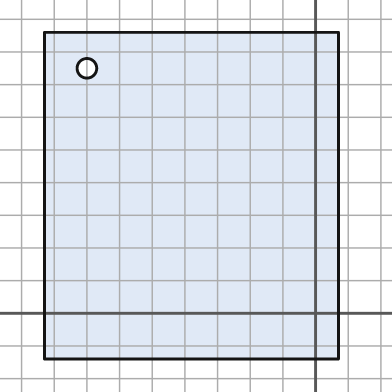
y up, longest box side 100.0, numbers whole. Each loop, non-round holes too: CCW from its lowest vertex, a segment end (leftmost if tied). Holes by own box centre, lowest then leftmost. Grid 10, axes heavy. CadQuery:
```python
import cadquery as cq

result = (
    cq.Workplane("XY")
    .moveTo(-83.0, -14.0)
    .lineTo(7.0, -14.0)
    .lineTo(7.0, 86.0)
    .lineTo(-83.0, 86.0)
    .close()
    .moveTo(-70.0, 75.0)
    .circle(3.0)
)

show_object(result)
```